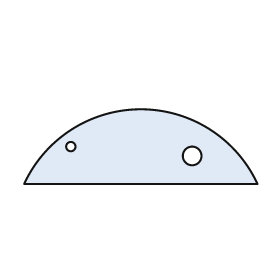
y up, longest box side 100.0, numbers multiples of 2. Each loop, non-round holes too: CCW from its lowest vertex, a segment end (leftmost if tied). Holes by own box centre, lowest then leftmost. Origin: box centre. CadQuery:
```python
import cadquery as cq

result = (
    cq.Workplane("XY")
    .moveTo(-50.0, -16.0)
    .lineTo(50.0, -16.0)
    .threePointArc((0.0, 16.0), (-50.0, -16.0))
    .close()
    .moveTo(22.0, -4.0)
    .circle(4.0)
    .moveTo(-30.0, 0.0)
    .circle(2.0)
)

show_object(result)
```